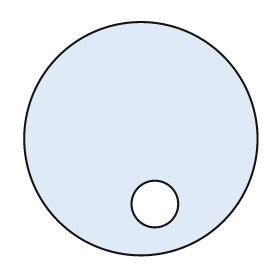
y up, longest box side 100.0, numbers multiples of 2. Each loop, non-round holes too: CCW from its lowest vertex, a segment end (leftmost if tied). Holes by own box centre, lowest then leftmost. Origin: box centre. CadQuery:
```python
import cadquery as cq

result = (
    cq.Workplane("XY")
    .moveTo(0.0, 0.0)
    .circle(50.0)
    .moveTo(6.0, -28.0)
    .circle(10.0)
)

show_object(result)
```